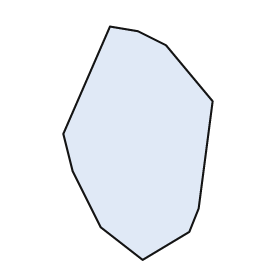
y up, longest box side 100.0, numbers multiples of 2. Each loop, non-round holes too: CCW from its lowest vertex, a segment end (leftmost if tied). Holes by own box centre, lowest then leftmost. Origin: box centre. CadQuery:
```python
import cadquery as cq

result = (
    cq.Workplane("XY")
    .moveTo(2.0, -50.0)
    .lineTo(22.0, -38.0)
    .lineTo(26.0, -28.0)
    .lineTo(32.0, 18.0)
    .lineTo(12.0, 42.0)
    .lineTo(0.0, 48.0)
    .lineTo(-12.0, 50.0)
    .lineTo(-32.0, 4.0)
    .lineTo(-28.0, -12.0)
    .lineTo(-16.0, -36.0)
    .close()
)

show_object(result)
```